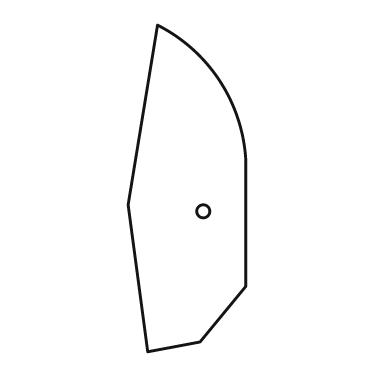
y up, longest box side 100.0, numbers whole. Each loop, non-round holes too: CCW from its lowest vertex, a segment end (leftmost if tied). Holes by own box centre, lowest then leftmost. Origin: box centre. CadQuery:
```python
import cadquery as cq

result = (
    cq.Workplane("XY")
    .moveTo(-12.0, -50.0)
    .lineTo(4.0, -47.0)
    .lineTo(18.0, -30.0)
    .lineTo(18.0, 9.0)
    .threePointArc((10.0, 33.0), (-9.0, 50.0))
    .lineTo(-18.0, -5.0)
    .close()
    .moveTo(5.0, -7.0)
    .circle(2.0)
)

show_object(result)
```